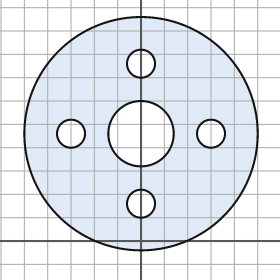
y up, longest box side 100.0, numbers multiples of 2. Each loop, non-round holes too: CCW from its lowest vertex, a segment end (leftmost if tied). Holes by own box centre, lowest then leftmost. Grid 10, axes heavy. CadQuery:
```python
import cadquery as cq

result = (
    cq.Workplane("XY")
    .moveTo(0.0, 46.0)
    .circle(50.0)
    .moveTo(0.0, 16.0)
    .circle(6.0)
    .moveTo(-30.0, 46.0)
    .circle(6.0)
    .moveTo(0.0, 46.0)
    .circle(14.0)
    .moveTo(30.0, 46.0)
    .circle(6.0)
    .moveTo(0.0, 76.0)
    .circle(6.0)
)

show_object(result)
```